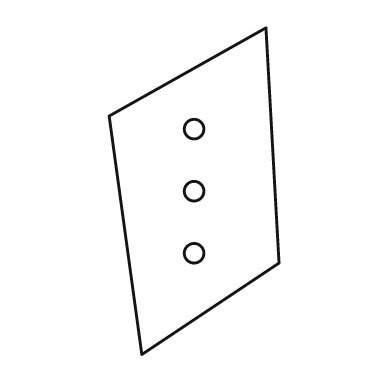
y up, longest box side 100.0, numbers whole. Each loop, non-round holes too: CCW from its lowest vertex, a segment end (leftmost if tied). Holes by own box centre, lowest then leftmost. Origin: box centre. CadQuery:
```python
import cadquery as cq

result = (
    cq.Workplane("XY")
    .moveTo(-16.0, -50.0)
    .lineTo(26.0, -22.0)
    .lineTo(22.0, 50.0)
    .lineTo(-26.0, 23.0)
    .close()
    .moveTo(0.0, -19.0)
    .circle(3.0)
    .moveTo(0.0, 0.0)
    .circle(3.0)
    .moveTo(0.0, 19.0)
    .circle(3.0)
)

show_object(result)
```